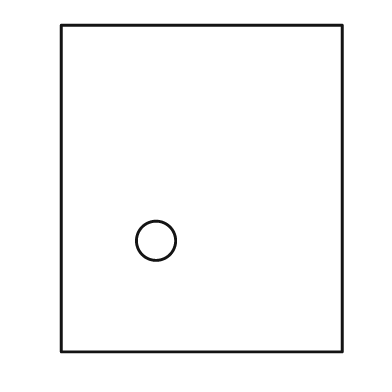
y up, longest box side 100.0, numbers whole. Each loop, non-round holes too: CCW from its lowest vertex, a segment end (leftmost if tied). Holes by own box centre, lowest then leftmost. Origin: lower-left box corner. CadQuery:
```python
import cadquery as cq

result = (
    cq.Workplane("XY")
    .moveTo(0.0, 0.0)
    .lineTo(86.0, 0.0)
    .lineTo(86.0, 100.0)
    .lineTo(0.0, 100.0)
    .close()
    .moveTo(29.0, 34.0)
    .circle(6.0)
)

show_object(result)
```